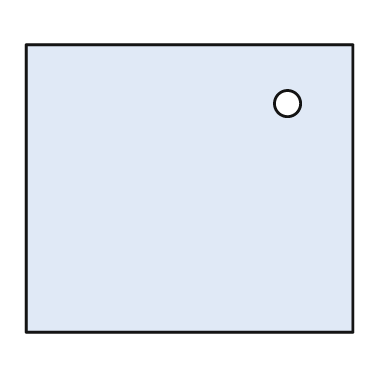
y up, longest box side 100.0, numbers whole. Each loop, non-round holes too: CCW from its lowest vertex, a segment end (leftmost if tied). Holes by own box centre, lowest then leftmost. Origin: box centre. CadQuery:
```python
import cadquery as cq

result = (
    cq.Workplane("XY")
    .moveTo(-50.0, -44.0)
    .lineTo(50.0, -44.0)
    .lineTo(50.0, 44.0)
    .lineTo(-50.0, 44.0)
    .close()
    .moveTo(30.0, 26.0)
    .circle(4.0)
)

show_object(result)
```